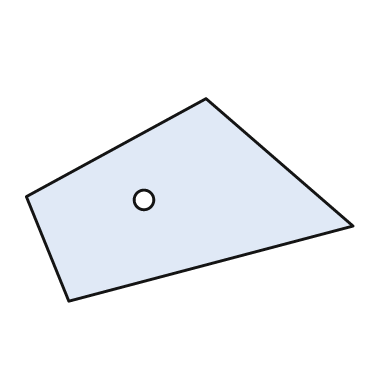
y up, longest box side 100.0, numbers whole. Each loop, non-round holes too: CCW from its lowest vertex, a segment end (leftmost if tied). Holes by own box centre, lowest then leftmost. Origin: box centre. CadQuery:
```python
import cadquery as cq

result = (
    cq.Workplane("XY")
    .moveTo(-37.0, -31.0)
    .lineTo(50.0, -8.0)
    .lineTo(5.0, 31.0)
    .lineTo(-50.0, 1.0)
    .close()
    .moveTo(-14.0, 0.0)
    .circle(3.0)
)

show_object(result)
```